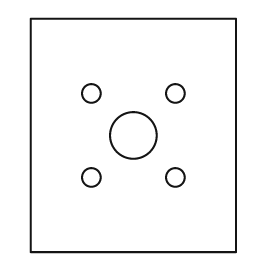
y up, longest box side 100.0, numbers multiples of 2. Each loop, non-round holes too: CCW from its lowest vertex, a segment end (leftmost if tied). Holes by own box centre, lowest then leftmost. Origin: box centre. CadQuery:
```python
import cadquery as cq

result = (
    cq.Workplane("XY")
    .moveTo(-44.0, -50.0)
    .lineTo(44.0, -50.0)
    .lineTo(44.0, 50.0)
    .lineTo(-44.0, 50.0)
    .close()
    .moveTo(-18.0, -18.0)
    .circle(4.0)
    .moveTo(18.0, -18.0)
    .circle(4.0)
    .moveTo(0.0, 0.0)
    .circle(10.0)
    .moveTo(-18.0, 18.0)
    .circle(4.0)
    .moveTo(18.0, 18.0)
    .circle(4.0)
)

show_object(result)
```